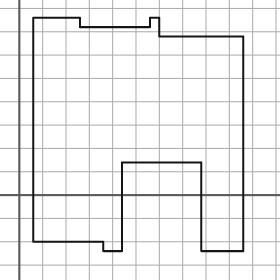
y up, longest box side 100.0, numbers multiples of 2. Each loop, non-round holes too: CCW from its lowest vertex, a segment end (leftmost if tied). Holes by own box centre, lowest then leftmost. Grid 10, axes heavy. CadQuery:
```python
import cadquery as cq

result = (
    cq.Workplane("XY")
    .moveTo(36.0, -24.0)
    .lineTo(44.0, -24.0)
    .lineTo(44.0, 14.0)
    .lineTo(78.0, 14.0)
    .lineTo(78.0, -24.0)
    .lineTo(96.0, -24.0)
    .lineTo(96.0, 68.0)
    .lineTo(60.0, 68.0)
    .lineTo(60.0, 76.0)
    .lineTo(56.0, 76.0)
    .lineTo(56.0, 72.0)
    .lineTo(26.0, 72.0)
    .lineTo(26.0, 76.0)
    .lineTo(6.0, 76.0)
    .lineTo(6.0, -20.0)
    .lineTo(36.0, -20.0)
    .close()
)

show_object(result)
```